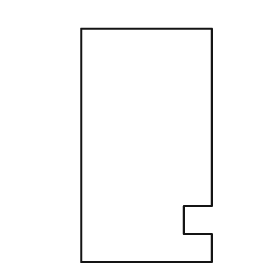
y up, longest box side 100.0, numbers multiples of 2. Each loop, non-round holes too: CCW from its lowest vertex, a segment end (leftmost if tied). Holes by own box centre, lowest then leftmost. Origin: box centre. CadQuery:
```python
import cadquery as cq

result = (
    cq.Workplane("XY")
    .moveTo(-28.0, -50.0)
    .lineTo(28.0, -50.0)
    .lineTo(28.0, -38.0)
    .lineTo(16.0, -38.0)
    .lineTo(16.0, -26.0)
    .lineTo(28.0, -26.0)
    .lineTo(28.0, 50.0)
    .lineTo(-28.0, 50.0)
    .close()
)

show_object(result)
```